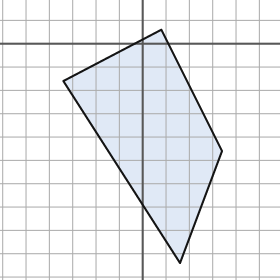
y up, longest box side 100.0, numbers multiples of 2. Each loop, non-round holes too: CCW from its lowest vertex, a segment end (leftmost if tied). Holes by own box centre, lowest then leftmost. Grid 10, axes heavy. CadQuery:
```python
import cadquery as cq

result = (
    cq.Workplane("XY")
    .moveTo(16.0, -94.0)
    .lineTo(34.0, -46.0)
    .lineTo(8.0, 6.0)
    .lineTo(-34.0, -16.0)
    .close()
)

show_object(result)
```